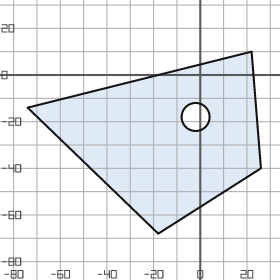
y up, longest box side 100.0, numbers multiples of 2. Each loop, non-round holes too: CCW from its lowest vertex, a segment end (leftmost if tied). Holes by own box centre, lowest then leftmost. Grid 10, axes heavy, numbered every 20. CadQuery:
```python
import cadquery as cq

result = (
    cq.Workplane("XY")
    .moveTo(-18.0, -68.0)
    .lineTo(26.0, -40.0)
    .lineTo(22.0, 10.0)
    .lineTo(-74.0, -14.0)
    .close()
    .moveTo(-2.0, -18.0)
    .circle(6.0)
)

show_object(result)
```